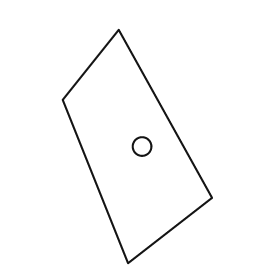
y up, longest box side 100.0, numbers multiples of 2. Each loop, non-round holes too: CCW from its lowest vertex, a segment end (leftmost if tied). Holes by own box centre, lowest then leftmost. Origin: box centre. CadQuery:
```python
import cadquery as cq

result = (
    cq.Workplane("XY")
    .moveTo(-4.0, -50.0)
    .lineTo(32.0, -22.0)
    .lineTo(-8.0, 50.0)
    .lineTo(-32.0, 20.0)
    .close()
    .moveTo(2.0, 0.0)
    .circle(4.0)
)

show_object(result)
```